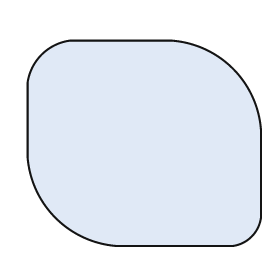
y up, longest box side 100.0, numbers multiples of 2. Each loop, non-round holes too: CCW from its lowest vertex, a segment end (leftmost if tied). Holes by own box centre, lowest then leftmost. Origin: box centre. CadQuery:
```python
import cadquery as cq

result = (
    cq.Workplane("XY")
    .moveTo(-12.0, -44.0)
    .lineTo(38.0, -44.0)
    .threePointArc((46.0, -40.0), (50.0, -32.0))
    .lineTo(50.0, 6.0)
    .threePointArc((38.0, 32.0), (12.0, 44.0))
    .lineTo(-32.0, 44.0)
    .threePointArc((-44.0, 38.0), (-50.0, 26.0))
    .lineTo(-50.0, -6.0)
    .threePointArc((-38.0, -32.0), (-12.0, -44.0))
    .close()
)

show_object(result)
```